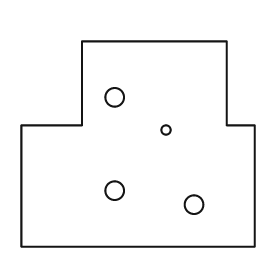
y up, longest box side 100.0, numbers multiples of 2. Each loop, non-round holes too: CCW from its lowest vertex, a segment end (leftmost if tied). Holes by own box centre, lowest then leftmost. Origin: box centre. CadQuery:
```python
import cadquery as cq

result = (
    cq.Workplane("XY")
    .moveTo(-50.0, -44.0)
    .lineTo(50.0, -44.0)
    .lineTo(50.0, 8.0)
    .lineTo(38.0, 8.0)
    .lineTo(38.0, 44.0)
    .lineTo(-24.0, 44.0)
    .lineTo(-24.0, 8.0)
    .lineTo(-50.0, 8.0)
    .close()
    .moveTo(24.0, -26.0)
    .circle(4.0)
    .moveTo(-10.0, -20.0)
    .circle(4.0)
    .moveTo(12.0, 6.0)
    .circle(2.0)
    .moveTo(-10.0, 20.0)
    .circle(4.0)
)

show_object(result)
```